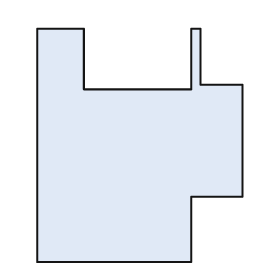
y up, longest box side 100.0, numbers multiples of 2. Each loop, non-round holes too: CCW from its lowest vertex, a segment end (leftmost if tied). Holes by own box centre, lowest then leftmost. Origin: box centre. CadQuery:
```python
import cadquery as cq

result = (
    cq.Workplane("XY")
    .moveTo(-44.0, -50.0)
    .lineTo(22.0, -50.0)
    .lineTo(22.0, -22.0)
    .lineTo(44.0, -22.0)
    .lineTo(44.0, 26.0)
    .lineTo(26.0, 26.0)
    .lineTo(26.0, 50.0)
    .lineTo(22.0, 50.0)
    .lineTo(22.0, 24.0)
    .lineTo(-24.0, 24.0)
    .lineTo(-24.0, 50.0)
    .lineTo(-44.0, 50.0)
    .close()
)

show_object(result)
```